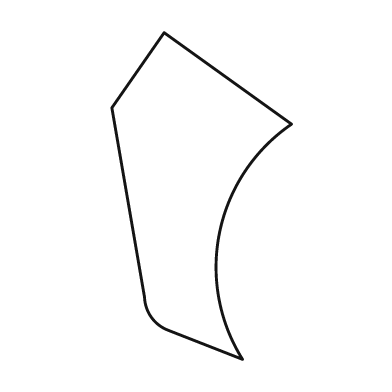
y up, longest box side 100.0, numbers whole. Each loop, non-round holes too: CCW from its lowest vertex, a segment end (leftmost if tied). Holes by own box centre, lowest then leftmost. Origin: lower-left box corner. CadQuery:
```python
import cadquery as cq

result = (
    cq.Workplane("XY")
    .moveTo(40.0, 0.0)
    .threePointArc((33.0, 39.0), (55.0, 72.0))
    .lineTo(16.0, 100.0)
    .lineTo(0.0, 77.0)
    .lineTo(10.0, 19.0)
    .threePointArc((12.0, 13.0), (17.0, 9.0))
    .close()
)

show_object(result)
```